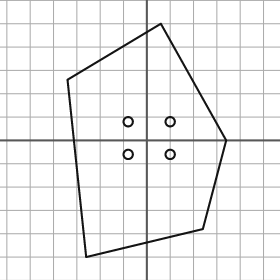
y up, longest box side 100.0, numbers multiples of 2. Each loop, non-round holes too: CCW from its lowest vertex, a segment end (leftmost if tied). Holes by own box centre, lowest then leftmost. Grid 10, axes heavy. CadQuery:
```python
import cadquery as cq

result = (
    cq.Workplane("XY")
    .moveTo(-26.0, -50.0)
    .lineTo(24.0, -38.0)
    .lineTo(34.0, 0.0)
    .lineTo(6.0, 50.0)
    .lineTo(-34.0, 26.0)
    .close()
    .moveTo(-8.0, -6.0)
    .circle(2.0)
    .moveTo(10.0, -6.0)
    .circle(2.0)
    .moveTo(-8.0, 8.0)
    .circle(2.0)
    .moveTo(10.0, 8.0)
    .circle(2.0)
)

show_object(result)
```